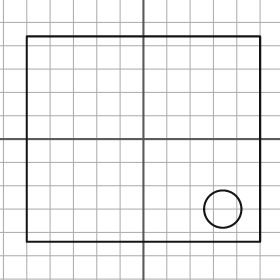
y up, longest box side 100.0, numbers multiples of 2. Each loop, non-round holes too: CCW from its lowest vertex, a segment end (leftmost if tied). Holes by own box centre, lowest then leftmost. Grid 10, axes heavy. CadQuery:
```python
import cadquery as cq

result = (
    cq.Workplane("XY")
    .moveTo(-50.0, -44.0)
    .lineTo(50.0, -44.0)
    .lineTo(50.0, 44.0)
    .lineTo(-50.0, 44.0)
    .close()
    .moveTo(34.0, -30.0)
    .circle(8.0)
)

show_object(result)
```